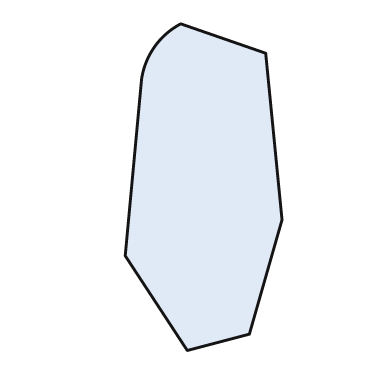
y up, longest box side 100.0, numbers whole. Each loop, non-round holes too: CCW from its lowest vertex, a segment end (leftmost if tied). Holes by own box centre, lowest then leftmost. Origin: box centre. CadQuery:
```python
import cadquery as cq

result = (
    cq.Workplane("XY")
    .moveTo(-5.0, -50.0)
    .lineTo(14.0, -45.0)
    .lineTo(24.0, -10.0)
    .lineTo(19.0, 41.0)
    .lineTo(-7.0, 50.0)
    .threePointArc((-15.0, 43.0), (-19.0, 33.0))
    .lineTo(-24.0, -21.0)
    .close()
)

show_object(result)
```